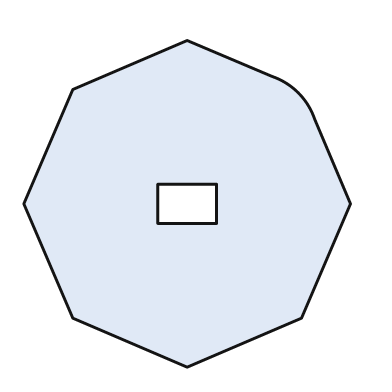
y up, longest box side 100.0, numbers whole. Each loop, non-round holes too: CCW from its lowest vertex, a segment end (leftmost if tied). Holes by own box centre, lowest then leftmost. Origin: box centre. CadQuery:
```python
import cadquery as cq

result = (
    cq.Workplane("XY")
    .moveTo(0.0, -50.0)
    .lineTo(35.0, -35.0)
    .lineTo(50.0, 0.0)
    .lineTo(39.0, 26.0)
    .threePointArc((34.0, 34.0), (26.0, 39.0))
    .lineTo(0.0, 50.0)
    .lineTo(-35.0, 35.0)
    .lineTo(-50.0, 0.0)
    .lineTo(-35.0, -35.0)
    .close()
    .moveTo(-9.0, -6.0)
    .lineTo(9.0, -6.0)
    .lineTo(9.0, 6.0)
    .lineTo(-9.0, 6.0)
    .close()
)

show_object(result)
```